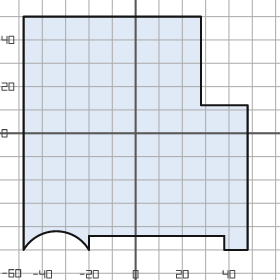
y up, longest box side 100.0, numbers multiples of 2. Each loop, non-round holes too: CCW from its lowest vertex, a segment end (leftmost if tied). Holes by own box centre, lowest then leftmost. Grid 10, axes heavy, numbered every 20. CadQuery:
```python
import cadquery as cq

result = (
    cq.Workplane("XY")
    .moveTo(-48.0, -50.0)
    .threePointArc((-34.0, -42.0), (-20.0, -50.0))
    .lineTo(-20.0, -44.0)
    .lineTo(38.0, -44.0)
    .lineTo(38.0, -50.0)
    .lineTo(48.0, -50.0)
    .lineTo(48.0, 12.0)
    .lineTo(28.0, 12.0)
    .lineTo(28.0, 50.0)
    .lineTo(-48.0, 50.0)
    .close()
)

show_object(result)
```